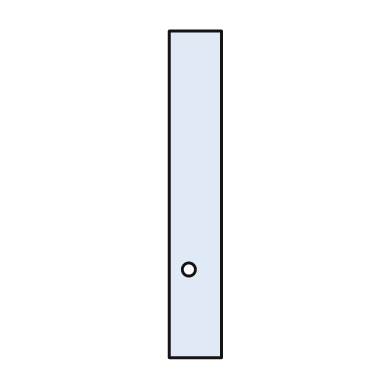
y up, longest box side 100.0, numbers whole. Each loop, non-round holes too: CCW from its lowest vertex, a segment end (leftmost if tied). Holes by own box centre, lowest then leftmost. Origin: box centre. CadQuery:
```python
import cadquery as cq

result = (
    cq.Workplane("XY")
    .moveTo(-8.0, -50.0)
    .lineTo(8.0, -50.0)
    .lineTo(8.0, 50.0)
    .lineTo(-8.0, 50.0)
    .close()
    .moveTo(-2.0, -23.0)
    .circle(2.0)
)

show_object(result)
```